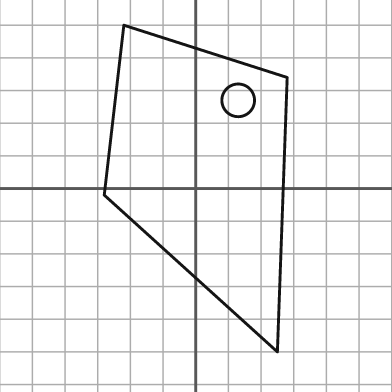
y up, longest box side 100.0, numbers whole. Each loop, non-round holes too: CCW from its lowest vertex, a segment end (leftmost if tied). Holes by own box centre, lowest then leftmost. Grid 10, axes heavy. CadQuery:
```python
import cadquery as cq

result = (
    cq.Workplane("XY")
    .moveTo(25.0, -50.0)
    .lineTo(28.0, 34.0)
    .lineTo(-22.0, 50.0)
    .lineTo(-28.0, -2.0)
    .close()
    .moveTo(13.0, 27.0)
    .circle(5.0)
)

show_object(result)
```